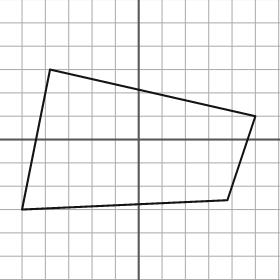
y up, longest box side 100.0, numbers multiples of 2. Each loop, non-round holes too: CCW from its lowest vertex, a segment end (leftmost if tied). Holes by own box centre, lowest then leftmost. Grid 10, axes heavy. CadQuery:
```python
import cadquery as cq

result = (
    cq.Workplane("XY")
    .moveTo(-50.0, -30.0)
    .lineTo(38.0, -26.0)
    .lineTo(50.0, 10.0)
    .lineTo(-38.0, 30.0)
    .close()
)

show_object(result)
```